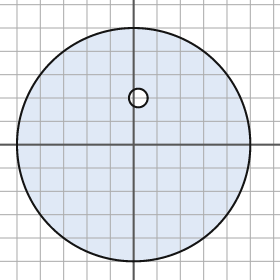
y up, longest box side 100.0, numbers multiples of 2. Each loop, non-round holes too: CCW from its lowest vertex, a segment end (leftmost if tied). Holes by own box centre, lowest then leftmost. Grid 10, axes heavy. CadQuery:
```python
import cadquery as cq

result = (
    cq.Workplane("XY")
    .moveTo(0.0, 0.0)
    .circle(50.0)
    .moveTo(2.0, 20.0)
    .circle(4.0)
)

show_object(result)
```